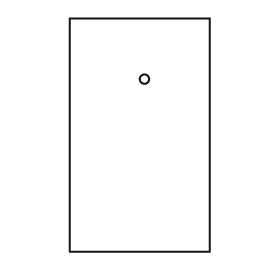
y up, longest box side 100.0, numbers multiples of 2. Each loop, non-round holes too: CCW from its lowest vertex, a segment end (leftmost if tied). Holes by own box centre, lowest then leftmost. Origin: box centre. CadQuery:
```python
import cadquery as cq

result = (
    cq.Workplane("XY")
    .moveTo(-30.0, -50.0)
    .lineTo(30.0, -50.0)
    .lineTo(30.0, 50.0)
    .lineTo(-30.0, 50.0)
    .close()
    .moveTo(2.0, 24.0)
    .circle(2.0)
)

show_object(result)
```